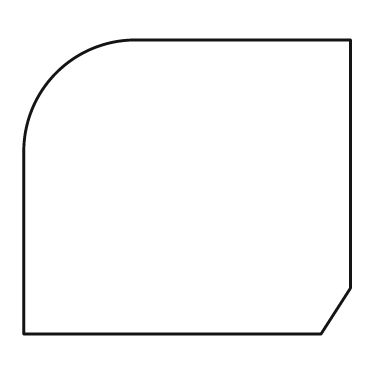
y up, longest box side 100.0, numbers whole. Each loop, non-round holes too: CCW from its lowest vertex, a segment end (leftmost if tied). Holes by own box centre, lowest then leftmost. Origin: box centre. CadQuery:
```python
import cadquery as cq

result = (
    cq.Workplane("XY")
    .moveTo(-50.0, -45.0)
    .lineTo(41.0, -45.0)
    .lineTo(50.0, -31.0)
    .lineTo(50.0, 45.0)
    .lineTo(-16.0, 45.0)
    .threePointArc((-40.0, 35.0), (-50.0, 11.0))
    .close()
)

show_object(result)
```